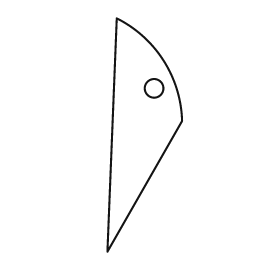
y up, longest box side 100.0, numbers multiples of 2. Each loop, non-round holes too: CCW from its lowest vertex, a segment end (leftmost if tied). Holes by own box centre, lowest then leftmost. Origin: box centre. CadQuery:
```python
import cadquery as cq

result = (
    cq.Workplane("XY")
    .moveTo(-16.0, -50.0)
    .lineTo(16.0, 6.0)
    .threePointArc((8.0, 32.0), (-12.0, 50.0))
    .close()
    .moveTo(4.0, 20.0)
    .circle(4.0)
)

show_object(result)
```